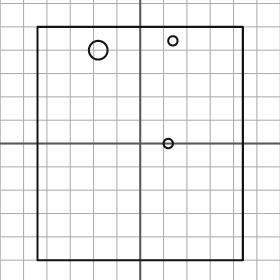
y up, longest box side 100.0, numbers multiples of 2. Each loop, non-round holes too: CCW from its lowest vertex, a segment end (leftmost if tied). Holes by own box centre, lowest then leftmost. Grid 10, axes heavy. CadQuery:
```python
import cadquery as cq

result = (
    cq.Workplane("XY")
    .moveTo(-44.0, -50.0)
    .lineTo(44.0, -50.0)
    .lineTo(44.0, 50.0)
    .lineTo(-44.0, 50.0)
    .close()
    .moveTo(12.0, 0.0)
    .circle(2.0)
    .moveTo(-18.0, 40.0)
    .circle(4.0)
    .moveTo(14.0, 44.0)
    .circle(2.0)
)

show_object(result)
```